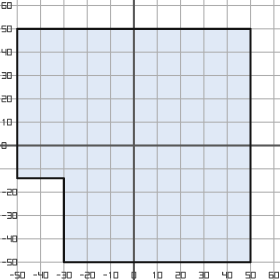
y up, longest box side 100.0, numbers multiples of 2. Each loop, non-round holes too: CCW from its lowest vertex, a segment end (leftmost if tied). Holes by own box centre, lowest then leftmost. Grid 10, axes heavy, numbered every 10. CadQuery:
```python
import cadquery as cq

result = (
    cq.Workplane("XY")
    .moveTo(-30.0, -50.0)
    .lineTo(50.0, -50.0)
    .lineTo(50.0, 50.0)
    .lineTo(-50.0, 50.0)
    .lineTo(-50.0, -14.0)
    .lineTo(-30.0, -14.0)
    .close()
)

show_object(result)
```